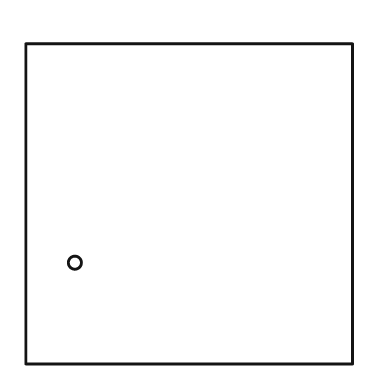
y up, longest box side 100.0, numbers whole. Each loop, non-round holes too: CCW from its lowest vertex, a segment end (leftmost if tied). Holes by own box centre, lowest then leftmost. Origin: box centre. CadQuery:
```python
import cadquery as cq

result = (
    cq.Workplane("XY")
    .moveTo(-50.0, -49.0)
    .lineTo(50.0, -49.0)
    .lineTo(50.0, 49.0)
    .lineTo(-50.0, 49.0)
    .close()
    .moveTo(-35.0, -18.0)
    .circle(2.0)
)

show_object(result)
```